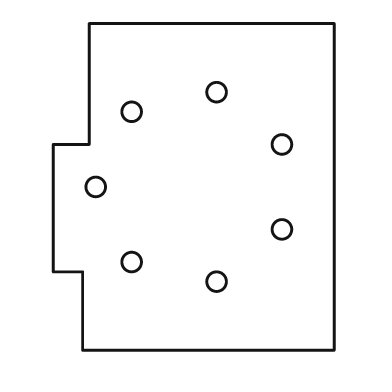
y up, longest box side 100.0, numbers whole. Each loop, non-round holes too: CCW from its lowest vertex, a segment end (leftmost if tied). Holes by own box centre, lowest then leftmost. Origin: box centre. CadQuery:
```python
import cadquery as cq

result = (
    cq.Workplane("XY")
    .moveTo(-34.0, -50.0)
    .lineTo(43.0, -50.0)
    .lineTo(43.0, 50.0)
    .lineTo(-32.0, 50.0)
    .lineTo(-32.0, 13.0)
    .lineTo(-43.0, 13.0)
    .lineTo(-43.0, -26.0)
    .lineTo(-34.0, -26.0)
    .close()
    .moveTo(7.0, -29.0)
    .circle(3.0)
    .moveTo(-19.0, -23.0)
    .circle(3.0)
    .moveTo(27.0, -13.0)
    .circle(3.0)
    .moveTo(-30.0, 0.0)
    .circle(3.0)
    .moveTo(27.0, 13.0)
    .circle(3.0)
    .moveTo(-19.0, 23.0)
    .circle(3.0)
    .moveTo(7.0, 29.0)
    .circle(3.0)
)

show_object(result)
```